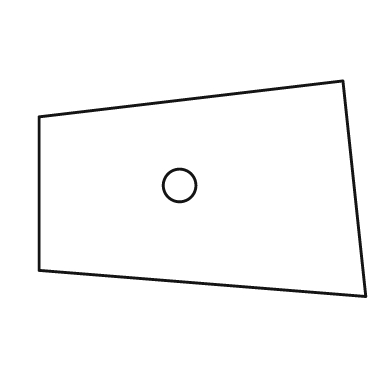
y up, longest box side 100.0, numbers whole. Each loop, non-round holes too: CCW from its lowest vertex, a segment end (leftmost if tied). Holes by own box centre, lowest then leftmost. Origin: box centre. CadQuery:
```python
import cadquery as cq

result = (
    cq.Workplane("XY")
    .moveTo(50.0, -33.0)
    .lineTo(43.0, 33.0)
    .lineTo(-50.0, 22.0)
    .lineTo(-50.0, -25.0)
    .close()
    .moveTo(-7.0, 1.0)
    .circle(5.0)
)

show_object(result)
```